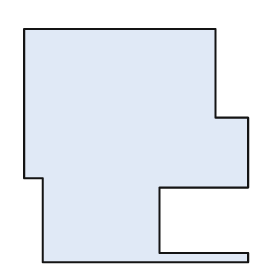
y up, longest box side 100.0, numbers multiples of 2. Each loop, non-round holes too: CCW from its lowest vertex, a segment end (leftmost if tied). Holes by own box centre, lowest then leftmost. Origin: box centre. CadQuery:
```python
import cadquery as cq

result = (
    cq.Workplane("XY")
    .moveTo(-40.0, -50.0)
    .lineTo(48.0, -50.0)
    .lineTo(48.0, -46.0)
    .lineTo(10.0, -46.0)
    .lineTo(10.0, -18.0)
    .lineTo(48.0, -18.0)
    .lineTo(48.0, 12.0)
    .lineTo(34.0, 12.0)
    .lineTo(34.0, 50.0)
    .lineTo(-48.0, 50.0)
    .lineTo(-48.0, -14.0)
    .lineTo(-40.0, -14.0)
    .close()
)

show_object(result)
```